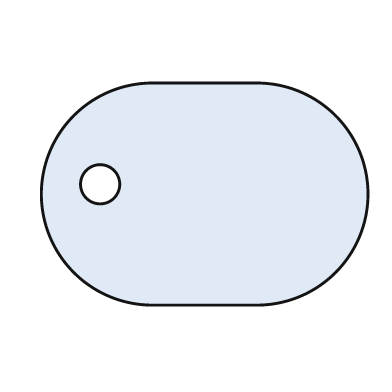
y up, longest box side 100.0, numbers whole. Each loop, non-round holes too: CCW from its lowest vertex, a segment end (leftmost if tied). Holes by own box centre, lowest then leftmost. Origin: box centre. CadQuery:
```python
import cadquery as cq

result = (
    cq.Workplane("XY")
    .moveTo(-16.0, -34.0)
    .lineTo(16.0, -34.0)
    .threePointArc((50.0, 0.0), (16.0, 34.0))
    .lineTo(-16.0, 34.0)
    .threePointArc((-50.0, 0.0), (-16.0, -34.0))
    .close()
    .moveTo(-32.0, 3.0)
    .circle(6.0)
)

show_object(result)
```